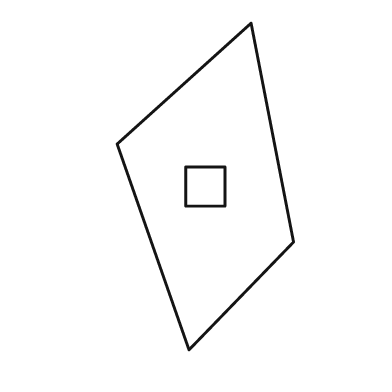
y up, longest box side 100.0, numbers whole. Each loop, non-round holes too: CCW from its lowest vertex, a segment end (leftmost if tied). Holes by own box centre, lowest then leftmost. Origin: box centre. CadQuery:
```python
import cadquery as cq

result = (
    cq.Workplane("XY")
    .moveTo(-5.0, -50.0)
    .lineTo(27.0, -17.0)
    .lineTo(14.0, 50.0)
    .lineTo(-27.0, 13.0)
    .close()
    .moveTo(-6.0, -6.0)
    .lineTo(6.0, -6.0)
    .lineTo(6.0, 6.0)
    .lineTo(-6.0, 6.0)
    .close()
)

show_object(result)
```